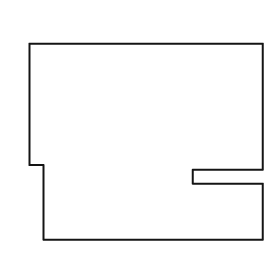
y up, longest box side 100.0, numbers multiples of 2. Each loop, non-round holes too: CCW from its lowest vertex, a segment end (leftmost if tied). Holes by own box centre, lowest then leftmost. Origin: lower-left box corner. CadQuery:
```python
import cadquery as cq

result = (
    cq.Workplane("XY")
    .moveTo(6.0, 0.0)
    .lineTo(100.0, 0.0)
    .lineTo(100.0, 24.0)
    .lineTo(70.0, 24.0)
    .lineTo(70.0, 30.0)
    .lineTo(100.0, 30.0)
    .lineTo(100.0, 84.0)
    .lineTo(0.0, 84.0)
    .lineTo(0.0, 32.0)
    .lineTo(6.0, 32.0)
    .close()
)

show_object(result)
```